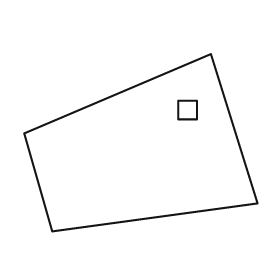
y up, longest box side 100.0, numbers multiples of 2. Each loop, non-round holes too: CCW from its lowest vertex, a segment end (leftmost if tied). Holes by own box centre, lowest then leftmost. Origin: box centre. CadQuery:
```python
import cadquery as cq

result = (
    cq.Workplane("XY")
    .moveTo(-38.0, -38.0)
    .lineTo(50.0, -26.0)
    .lineTo(30.0, 38.0)
    .lineTo(-50.0, 4.0)
    .close()
    .moveTo(16.0, 10.0)
    .lineTo(24.0, 10.0)
    .lineTo(24.0, 18.0)
    .lineTo(16.0, 18.0)
    .close()
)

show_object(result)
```